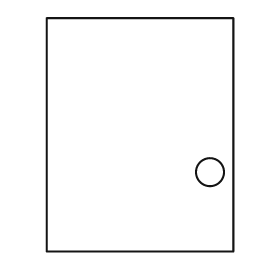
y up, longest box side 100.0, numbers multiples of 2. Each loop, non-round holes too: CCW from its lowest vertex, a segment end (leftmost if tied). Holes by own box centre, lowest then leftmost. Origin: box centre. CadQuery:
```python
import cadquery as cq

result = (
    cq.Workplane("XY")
    .moveTo(-40.0, -50.0)
    .lineTo(40.0, -50.0)
    .lineTo(40.0, 50.0)
    .lineTo(-40.0, 50.0)
    .close()
    .moveTo(30.0, -16.0)
    .circle(6.0)
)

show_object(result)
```